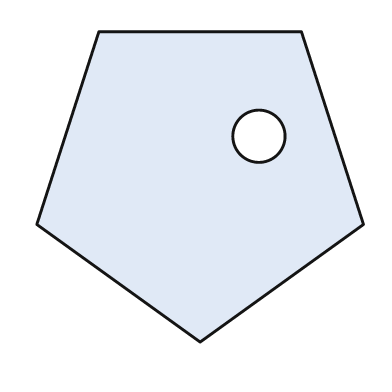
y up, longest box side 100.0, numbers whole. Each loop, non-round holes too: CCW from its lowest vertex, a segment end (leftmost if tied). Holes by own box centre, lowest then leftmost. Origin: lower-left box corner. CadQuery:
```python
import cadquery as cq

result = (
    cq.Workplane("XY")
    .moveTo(50.0, 0.0)
    .lineTo(100.0, 36.0)
    .lineTo(81.0, 95.0)
    .lineTo(19.0, 95.0)
    .lineTo(0.0, 36.0)
    .close()
    .moveTo(68.0, 63.0)
    .circle(8.0)
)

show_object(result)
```